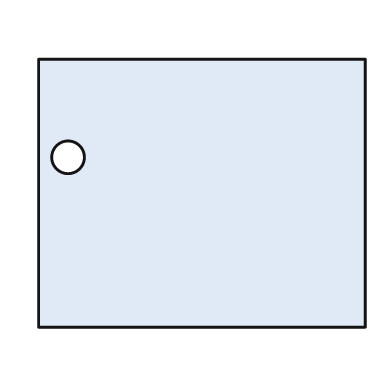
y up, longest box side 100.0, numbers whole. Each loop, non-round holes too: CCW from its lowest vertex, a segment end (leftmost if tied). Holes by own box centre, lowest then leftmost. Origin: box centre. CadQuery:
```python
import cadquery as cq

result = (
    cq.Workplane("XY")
    .moveTo(-50.0, -41.0)
    .lineTo(50.0, -41.0)
    .lineTo(50.0, 41.0)
    .lineTo(-50.0, 41.0)
    .close()
    .moveTo(-41.0, 11.0)
    .circle(5.0)
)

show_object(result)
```